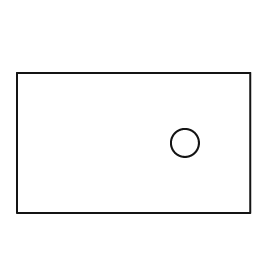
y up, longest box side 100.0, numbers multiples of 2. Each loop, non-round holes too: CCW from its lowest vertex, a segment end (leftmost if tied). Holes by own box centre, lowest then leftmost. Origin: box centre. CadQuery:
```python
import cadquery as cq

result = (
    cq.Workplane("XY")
    .moveTo(-50.0, -30.0)
    .lineTo(50.0, -30.0)
    .lineTo(50.0, 30.0)
    .lineTo(-50.0, 30.0)
    .close()
    .moveTo(22.0, 0.0)
    .circle(6.0)
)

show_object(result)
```